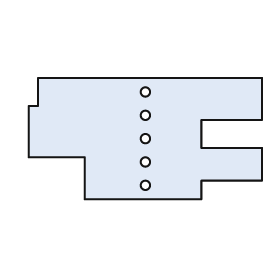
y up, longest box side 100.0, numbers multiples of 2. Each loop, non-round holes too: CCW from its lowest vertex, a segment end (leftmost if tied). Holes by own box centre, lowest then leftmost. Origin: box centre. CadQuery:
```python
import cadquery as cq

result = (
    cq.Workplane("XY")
    .moveTo(-26.0, -26.0)
    .lineTo(24.0, -26.0)
    .lineTo(24.0, -18.0)
    .lineTo(50.0, -18.0)
    .lineTo(50.0, -4.0)
    .lineTo(24.0, -4.0)
    .lineTo(24.0, 8.0)
    .lineTo(50.0, 8.0)
    .lineTo(50.0, 26.0)
    .lineTo(-46.0, 26.0)
    .lineTo(-46.0, 14.0)
    .lineTo(-50.0, 14.0)
    .lineTo(-50.0, -8.0)
    .lineTo(-26.0, -8.0)
    .close()
    .moveTo(0.0, -20.0)
    .circle(2.0)
    .moveTo(0.0, -10.0)
    .circle(2.0)
    .moveTo(0.0, 0.0)
    .circle(2.0)
    .moveTo(0.0, 10.0)
    .circle(2.0)
    .moveTo(0.0, 20.0)
    .circle(2.0)
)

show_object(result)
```